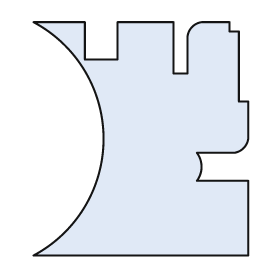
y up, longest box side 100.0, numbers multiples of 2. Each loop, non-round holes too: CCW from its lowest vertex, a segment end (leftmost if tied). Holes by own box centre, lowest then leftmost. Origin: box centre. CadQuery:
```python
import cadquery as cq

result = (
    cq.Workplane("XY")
    .moveTo(-46.0, -50.0)
    .lineTo(46.0, -50.0)
    .lineTo(46.0, -18.0)
    .lineTo(24.0, -18.0)
    .threePointArc((26.0, -12.0), (24.0, -6.0))
    .lineTo(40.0, -6.0)
    .threePointArc((44.0, -4.0), (46.0, 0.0))
    .lineTo(46.0, 16.0)
    .lineTo(42.0, 16.0)
    .lineTo(42.0, 46.0)
    .lineTo(38.0, 46.0)
    .lineTo(38.0, 50.0)
    .lineTo(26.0, 50.0)
    .threePointArc((22.0, 48.0), (20.0, 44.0))
    .lineTo(20.0, 28.0)
    .lineTo(14.0, 28.0)
    .lineTo(14.0, 50.0)
    .lineTo(-10.0, 50.0)
    .lineTo(-10.0, 34.0)
    .lineTo(-24.0, 34.0)
    .lineTo(-24.0, 50.0)
    .lineTo(-46.0, 50.0)
    .threePointArc((-16.0, 0.0), (-46.0, -50.0))
    .close()
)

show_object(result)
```